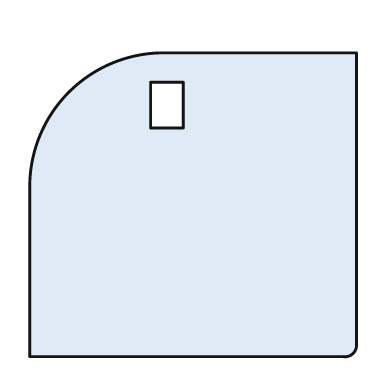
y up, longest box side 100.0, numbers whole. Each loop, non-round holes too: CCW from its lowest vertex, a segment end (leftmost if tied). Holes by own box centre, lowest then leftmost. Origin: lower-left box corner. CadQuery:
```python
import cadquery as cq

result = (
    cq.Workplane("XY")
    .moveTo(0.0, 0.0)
    .lineTo(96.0, 0.0)
    .threePointArc((99.0, 1.0), (100.0, 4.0))
    .lineTo(100.0, 93.0)
    .lineTo(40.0, 93.0)
    .threePointArc((12.0, 81.0), (0.0, 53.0))
    .close()
    .moveTo(37.0, 70.0)
    .lineTo(47.0, 70.0)
    .lineTo(47.0, 84.0)
    .lineTo(37.0, 84.0)
    .close()
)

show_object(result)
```